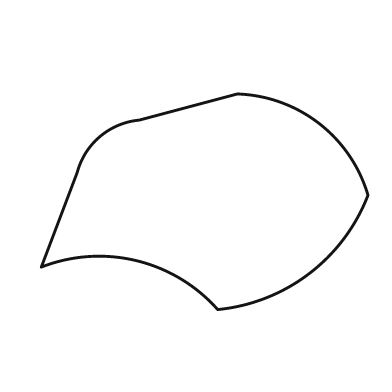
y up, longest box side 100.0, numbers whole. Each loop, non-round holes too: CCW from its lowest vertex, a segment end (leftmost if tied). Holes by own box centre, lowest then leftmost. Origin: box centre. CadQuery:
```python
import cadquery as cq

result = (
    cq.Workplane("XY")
    .moveTo(4.0, -33.0)
    .threePointArc((32.0, -22.0), (50.0, 2.0))
    .threePointArc((35.0, 24.0), (10.0, 33.0))
    .lineTo(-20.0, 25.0)
    .threePointArc((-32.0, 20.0), (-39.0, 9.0))
    .lineTo(-50.0, -20.0)
    .threePointArc((-21.0, -18.0), (4.0, -33.0))
    .close()
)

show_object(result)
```